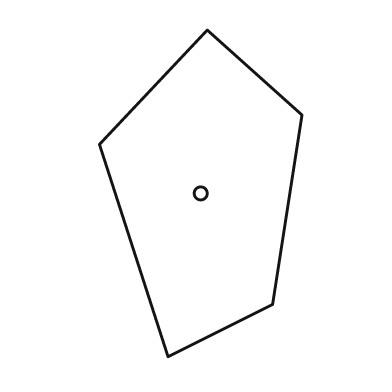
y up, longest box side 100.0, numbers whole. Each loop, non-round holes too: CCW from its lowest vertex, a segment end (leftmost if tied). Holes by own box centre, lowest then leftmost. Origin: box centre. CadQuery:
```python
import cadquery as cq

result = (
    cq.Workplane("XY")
    .moveTo(-10.0, -50.0)
    .lineTo(22.0, -34.0)
    .lineTo(31.0, 24.0)
    .lineTo(2.0, 50.0)
    .lineTo(-31.0, 15.0)
    .close()
    .moveTo(0.0, 0.0)
    .circle(2.0)
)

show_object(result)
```